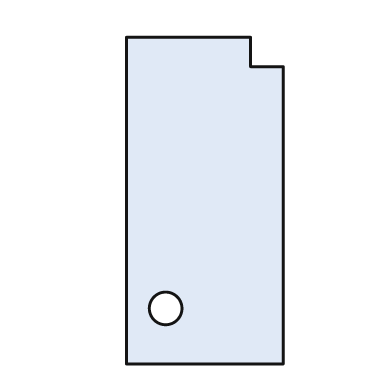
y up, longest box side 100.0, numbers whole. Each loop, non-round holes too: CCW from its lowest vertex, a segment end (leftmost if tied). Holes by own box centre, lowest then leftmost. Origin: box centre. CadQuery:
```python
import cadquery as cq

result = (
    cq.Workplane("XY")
    .moveTo(-24.0, -50.0)
    .lineTo(24.0, -50.0)
    .lineTo(24.0, 41.0)
    .lineTo(14.0, 41.0)
    .lineTo(14.0, 50.0)
    .lineTo(-24.0, 50.0)
    .close()
    .moveTo(-12.0, -33.0)
    .circle(5.0)
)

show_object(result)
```